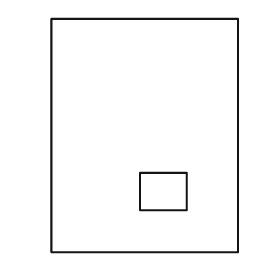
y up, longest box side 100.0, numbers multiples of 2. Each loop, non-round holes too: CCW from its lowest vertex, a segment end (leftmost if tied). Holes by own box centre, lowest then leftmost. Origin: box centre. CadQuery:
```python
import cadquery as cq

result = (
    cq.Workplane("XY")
    .moveTo(-40.0, -50.0)
    .lineTo(40.0, -50.0)
    .lineTo(40.0, 50.0)
    .lineTo(-40.0, 50.0)
    .close()
    .moveTo(-2.0, -32.0)
    .lineTo(18.0, -32.0)
    .lineTo(18.0, -16.0)
    .lineTo(-2.0, -16.0)
    .close()
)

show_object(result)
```